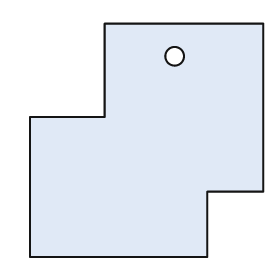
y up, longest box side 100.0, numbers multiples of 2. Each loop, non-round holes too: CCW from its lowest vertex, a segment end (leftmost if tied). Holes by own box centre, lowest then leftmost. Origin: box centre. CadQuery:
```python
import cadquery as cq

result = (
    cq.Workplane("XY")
    .moveTo(-50.0, -50.0)
    .lineTo(26.0, -50.0)
    .lineTo(26.0, -22.0)
    .lineTo(50.0, -22.0)
    .lineTo(50.0, 50.0)
    .lineTo(-18.0, 50.0)
    .lineTo(-18.0, 10.0)
    .lineTo(-50.0, 10.0)
    .close()
    .moveTo(12.0, 36.0)
    .circle(4.0)
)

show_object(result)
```